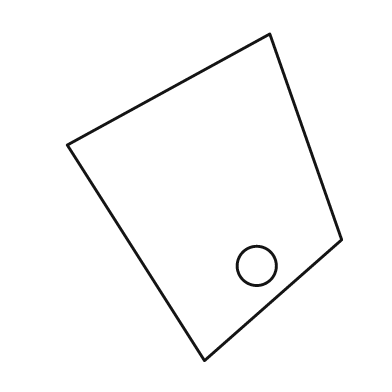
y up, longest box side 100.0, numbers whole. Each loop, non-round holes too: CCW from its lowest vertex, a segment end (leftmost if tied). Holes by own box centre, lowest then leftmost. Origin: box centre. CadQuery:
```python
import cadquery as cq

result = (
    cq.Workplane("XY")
    .moveTo(0.0, -50.0)
    .lineTo(42.0, -13.0)
    .lineTo(20.0, 50.0)
    .lineTo(-42.0, 16.0)
    .close()
    .moveTo(16.0, -21.0)
    .circle(6.0)
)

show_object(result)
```